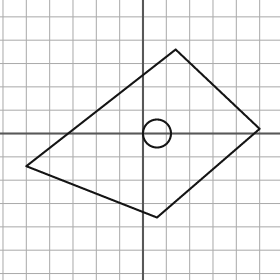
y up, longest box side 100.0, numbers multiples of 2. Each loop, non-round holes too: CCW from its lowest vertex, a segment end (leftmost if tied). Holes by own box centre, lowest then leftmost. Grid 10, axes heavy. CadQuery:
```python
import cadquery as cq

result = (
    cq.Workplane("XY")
    .moveTo(6.0, -36.0)
    .lineTo(50.0, 2.0)
    .lineTo(14.0, 36.0)
    .lineTo(-50.0, -14.0)
    .close()
    .moveTo(6.0, 0.0)
    .circle(6.0)
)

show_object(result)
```